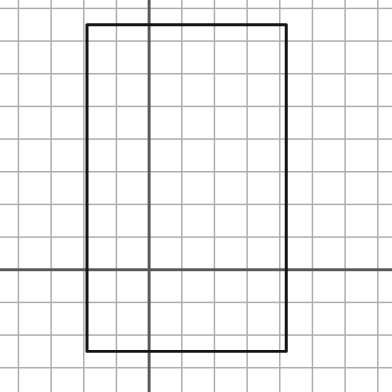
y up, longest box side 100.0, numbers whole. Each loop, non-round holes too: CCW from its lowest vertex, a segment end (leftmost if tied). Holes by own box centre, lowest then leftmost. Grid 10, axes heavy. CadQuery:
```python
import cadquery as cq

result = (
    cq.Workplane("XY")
    .moveTo(-19.0, -25.0)
    .lineTo(42.0, -25.0)
    .lineTo(42.0, 75.0)
    .lineTo(-19.0, 75.0)
    .close()
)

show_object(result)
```